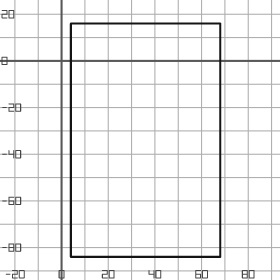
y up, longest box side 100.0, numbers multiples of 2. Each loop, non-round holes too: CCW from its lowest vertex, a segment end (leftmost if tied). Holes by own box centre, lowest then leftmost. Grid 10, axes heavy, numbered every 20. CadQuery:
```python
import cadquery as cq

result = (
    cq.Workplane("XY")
    .moveTo(4.0, -84.0)
    .lineTo(68.0, -84.0)
    .lineTo(68.0, 16.0)
    .lineTo(4.0, 16.0)
    .close()
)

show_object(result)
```